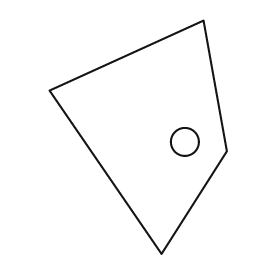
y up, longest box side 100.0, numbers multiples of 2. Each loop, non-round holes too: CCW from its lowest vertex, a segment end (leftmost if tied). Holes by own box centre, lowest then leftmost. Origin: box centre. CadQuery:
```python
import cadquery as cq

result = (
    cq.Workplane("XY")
    .moveTo(10.0, -50.0)
    .lineTo(38.0, -6.0)
    .lineTo(28.0, 50.0)
    .lineTo(-38.0, 20.0)
    .close()
    .moveTo(20.0, -2.0)
    .circle(6.0)
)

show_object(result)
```